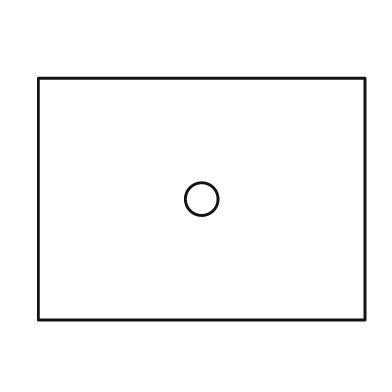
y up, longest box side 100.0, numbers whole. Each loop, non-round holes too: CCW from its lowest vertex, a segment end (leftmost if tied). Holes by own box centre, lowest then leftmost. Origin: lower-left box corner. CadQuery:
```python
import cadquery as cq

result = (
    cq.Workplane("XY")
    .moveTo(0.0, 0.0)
    .lineTo(100.0, 0.0)
    .lineTo(100.0, 74.0)
    .lineTo(0.0, 74.0)
    .close()
    .moveTo(50.0, 37.0)
    .circle(5.0)
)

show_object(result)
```